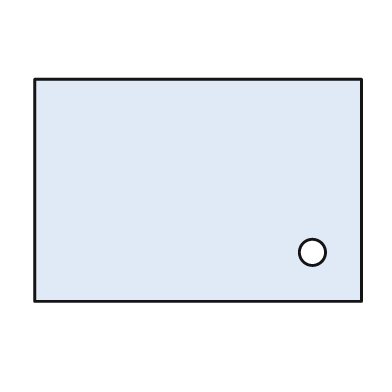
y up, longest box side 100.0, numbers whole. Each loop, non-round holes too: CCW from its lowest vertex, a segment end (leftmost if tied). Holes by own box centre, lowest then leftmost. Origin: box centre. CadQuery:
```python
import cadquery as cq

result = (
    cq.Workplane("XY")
    .moveTo(-50.0, -34.0)
    .lineTo(50.0, -34.0)
    .lineTo(50.0, 34.0)
    .lineTo(-50.0, 34.0)
    .close()
    .moveTo(35.0, -19.0)
    .circle(4.0)
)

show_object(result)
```